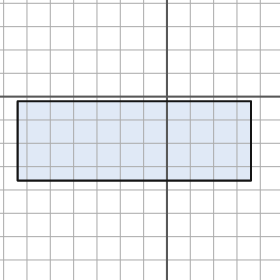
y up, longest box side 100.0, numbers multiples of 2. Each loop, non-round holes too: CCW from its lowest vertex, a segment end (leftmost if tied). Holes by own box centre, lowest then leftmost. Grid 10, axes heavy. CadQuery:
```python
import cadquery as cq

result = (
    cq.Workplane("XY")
    .moveTo(-64.0, -36.0)
    .lineTo(36.0, -36.0)
    .lineTo(36.0, -2.0)
    .lineTo(-64.0, -2.0)
    .close()
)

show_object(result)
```